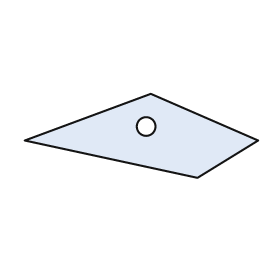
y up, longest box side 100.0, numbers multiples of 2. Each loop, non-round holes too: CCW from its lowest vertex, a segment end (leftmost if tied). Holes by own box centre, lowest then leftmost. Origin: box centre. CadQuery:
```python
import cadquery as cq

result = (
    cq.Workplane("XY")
    .moveTo(24.0, -18.0)
    .lineTo(50.0, -2.0)
    .lineTo(4.0, 18.0)
    .lineTo(-50.0, -2.0)
    .close()
    .moveTo(2.0, 4.0)
    .circle(4.0)
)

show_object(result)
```